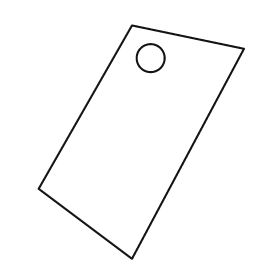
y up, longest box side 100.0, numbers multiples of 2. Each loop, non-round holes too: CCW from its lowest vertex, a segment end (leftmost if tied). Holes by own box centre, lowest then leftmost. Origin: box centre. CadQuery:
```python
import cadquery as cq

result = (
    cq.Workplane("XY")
    .moveTo(-4.0, -50.0)
    .lineTo(44.0, 40.0)
    .lineTo(-4.0, 50.0)
    .lineTo(-44.0, -20.0)
    .close()
    .moveTo(4.0, 36.0)
    .circle(6.0)
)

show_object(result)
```